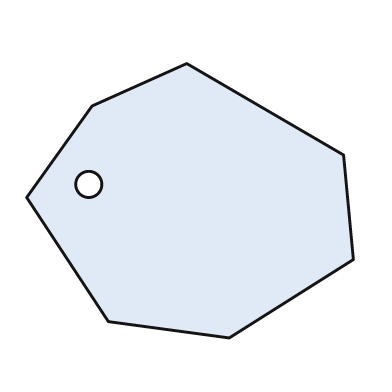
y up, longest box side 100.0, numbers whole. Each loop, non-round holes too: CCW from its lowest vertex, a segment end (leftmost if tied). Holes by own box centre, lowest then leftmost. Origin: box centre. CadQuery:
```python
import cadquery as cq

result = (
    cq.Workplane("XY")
    .moveTo(12.0, -42.0)
    .lineTo(50.0, -18.0)
    .lineTo(47.0, 14.0)
    .lineTo(-1.0, 42.0)
    .lineTo(-30.0, 29.0)
    .lineTo(-50.0, 1.0)
    .lineTo(-25.0, -37.0)
    .close()
    .moveTo(-31.0, 5.0)
    .circle(4.0)
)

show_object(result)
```